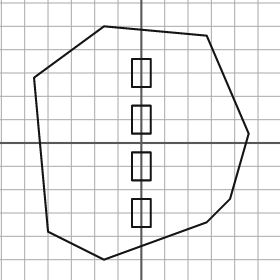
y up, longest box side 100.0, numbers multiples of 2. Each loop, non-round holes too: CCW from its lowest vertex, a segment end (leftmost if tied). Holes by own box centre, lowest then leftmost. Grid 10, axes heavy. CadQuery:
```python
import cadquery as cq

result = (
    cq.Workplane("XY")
    .moveTo(-16.0, -50.0)
    .lineTo(28.0, -34.0)
    .lineTo(38.0, -24.0)
    .lineTo(46.0, 4.0)
    .lineTo(28.0, 46.0)
    .lineTo(-16.0, 50.0)
    .lineTo(-46.0, 28.0)
    .lineTo(-40.0, -38.0)
    .close()
    .moveTo(-4.0, -36.0)
    .lineTo(4.0, -36.0)
    .lineTo(4.0, -24.0)
    .lineTo(-4.0, -24.0)
    .close()
    .moveTo(-4.0, -16.0)
    .lineTo(4.0, -16.0)
    .lineTo(4.0, -4.0)
    .lineTo(-4.0, -4.0)
    .close()
    .moveTo(-4.0, 4.0)
    .lineTo(4.0, 4.0)
    .lineTo(4.0, 16.0)
    .lineTo(-4.0, 16.0)
    .close()
    .moveTo(-4.0, 24.0)
    .lineTo(4.0, 24.0)
    .lineTo(4.0, 36.0)
    .lineTo(-4.0, 36.0)
    .close()
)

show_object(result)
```